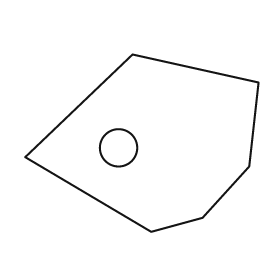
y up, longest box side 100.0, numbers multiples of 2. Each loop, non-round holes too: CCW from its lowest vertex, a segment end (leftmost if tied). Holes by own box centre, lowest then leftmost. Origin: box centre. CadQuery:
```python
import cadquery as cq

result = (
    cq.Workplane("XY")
    .moveTo(4.0, -38.0)
    .lineTo(26.0, -32.0)
    .lineTo(46.0, -10.0)
    .lineTo(50.0, 26.0)
    .lineTo(-4.0, 38.0)
    .lineTo(-50.0, -6.0)
    .close()
    .moveTo(-10.0, -2.0)
    .circle(8.0)
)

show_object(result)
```